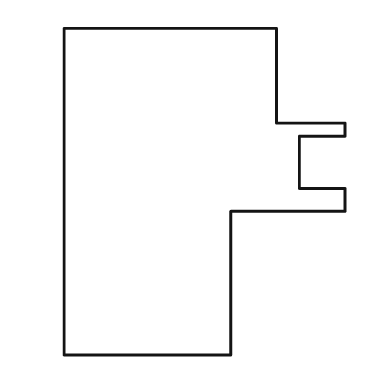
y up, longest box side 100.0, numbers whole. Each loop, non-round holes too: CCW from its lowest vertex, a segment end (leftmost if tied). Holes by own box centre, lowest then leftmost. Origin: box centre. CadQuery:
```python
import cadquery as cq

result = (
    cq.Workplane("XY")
    .moveTo(-43.0, -50.0)
    .lineTo(8.0, -50.0)
    .lineTo(8.0, -6.0)
    .lineTo(43.0, -6.0)
    .lineTo(43.0, 1.0)
    .lineTo(29.0, 1.0)
    .lineTo(29.0, 17.0)
    .lineTo(43.0, 17.0)
    .lineTo(43.0, 21.0)
    .lineTo(22.0, 21.0)
    .lineTo(22.0, 50.0)
    .lineTo(-43.0, 50.0)
    .close()
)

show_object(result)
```